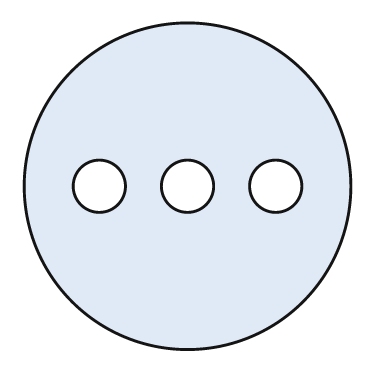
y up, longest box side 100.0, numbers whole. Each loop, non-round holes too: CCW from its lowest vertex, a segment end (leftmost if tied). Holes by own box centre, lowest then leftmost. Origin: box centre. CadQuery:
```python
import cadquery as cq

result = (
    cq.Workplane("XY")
    .moveTo(0.0, 0.0)
    .circle(50.0)
    .moveTo(-27.0, 0.0)
    .circle(8.0)
    .moveTo(0.0, 0.0)
    .circle(8.0)
    .moveTo(27.0, 0.0)
    .circle(8.0)
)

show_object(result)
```